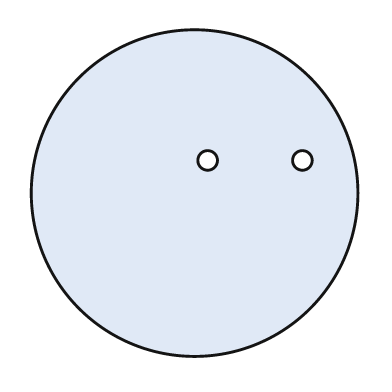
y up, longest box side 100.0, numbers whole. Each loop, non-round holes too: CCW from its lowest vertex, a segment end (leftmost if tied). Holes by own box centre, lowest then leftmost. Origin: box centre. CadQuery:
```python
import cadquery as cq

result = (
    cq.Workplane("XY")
    .moveTo(0.0, 0.0)
    .circle(50.0)
    .moveTo(4.0, 10.0)
    .circle(3.0)
    .moveTo(33.0, 10.0)
    .circle(3.0)
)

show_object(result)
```